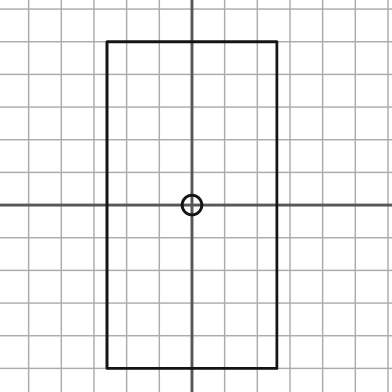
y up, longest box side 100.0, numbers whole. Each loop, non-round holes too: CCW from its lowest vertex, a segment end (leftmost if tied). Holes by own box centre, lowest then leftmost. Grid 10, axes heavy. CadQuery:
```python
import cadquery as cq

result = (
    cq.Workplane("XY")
    .moveTo(-26.0, -50.0)
    .lineTo(26.0, -50.0)
    .lineTo(26.0, 50.0)
    .lineTo(-26.0, 50.0)
    .close()
    .moveTo(0.0, 0.0)
    .circle(3.0)
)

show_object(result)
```